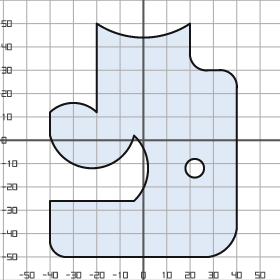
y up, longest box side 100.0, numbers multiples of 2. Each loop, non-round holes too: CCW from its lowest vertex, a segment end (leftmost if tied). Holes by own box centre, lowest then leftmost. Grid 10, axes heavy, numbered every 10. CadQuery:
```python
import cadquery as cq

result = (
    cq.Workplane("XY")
    .moveTo(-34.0, -50.0)
    .lineTo(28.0, -50.0)
    .threePointArc((36.0, -46.0), (40.0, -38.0))
    .lineTo(40.0, 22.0)
    .threePointArc((38.0, 28.0), (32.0, 30.0))
    .lineTo(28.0, 30.0)
    .threePointArc((22.0, 32.0), (20.0, 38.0))
    .lineTo(20.0, 50.0)
    .threePointArc((0.0, 44.0), (-20.0, 50.0))
    .lineTo(-20.0, 12.0)
    .threePointArc((-30.0, 16.0), (-40.0, 12.0))
    .lineTo(-40.0, 2.0)
    .threePointArc((-22.0, -12.0), (-4.0, 2.0))
    .threePointArc((2.0, -12.0), (-4.0, -26.0))
    .lineTo(-40.0, -26.0)
    .lineTo(-40.0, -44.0)
    .threePointArc((-38.0, -48.0), (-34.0, -50.0))
    .close()
    .moveTo(22.0, -12.0)
    .circle(4.0)
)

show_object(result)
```